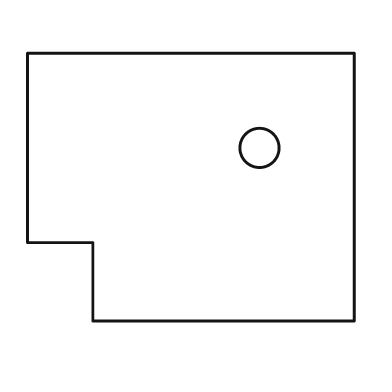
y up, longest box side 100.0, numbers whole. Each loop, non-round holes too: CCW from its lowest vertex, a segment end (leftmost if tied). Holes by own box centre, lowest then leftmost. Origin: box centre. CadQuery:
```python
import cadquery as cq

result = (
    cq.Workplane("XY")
    .moveTo(-30.0, -41.0)
    .lineTo(50.0, -41.0)
    .lineTo(50.0, 41.0)
    .lineTo(-50.0, 41.0)
    .lineTo(-50.0, -17.0)
    .lineTo(-30.0, -17.0)
    .close()
    .moveTo(21.0, 12.0)
    .circle(6.0)
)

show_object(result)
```